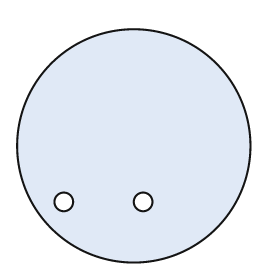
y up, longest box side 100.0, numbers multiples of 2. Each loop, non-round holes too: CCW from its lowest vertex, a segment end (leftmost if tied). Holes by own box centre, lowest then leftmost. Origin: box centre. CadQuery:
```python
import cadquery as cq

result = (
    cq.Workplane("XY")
    .moveTo(0.0, 0.0)
    .circle(50.0)
    .moveTo(-30.0, -24.0)
    .circle(4.0)
    .moveTo(4.0, -24.0)
    .circle(4.0)
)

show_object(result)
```